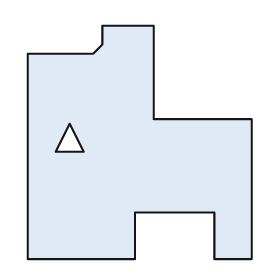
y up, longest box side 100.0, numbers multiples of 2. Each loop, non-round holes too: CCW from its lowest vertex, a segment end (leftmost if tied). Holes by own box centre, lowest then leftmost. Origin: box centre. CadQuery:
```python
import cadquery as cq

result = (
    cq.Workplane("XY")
    .moveTo(-48.0, -50.0)
    .lineTo(-2.0, -50.0)
    .lineTo(-2.0, -30.0)
    .lineTo(32.0, -30.0)
    .lineTo(32.0, -50.0)
    .lineTo(48.0, -50.0)
    .lineTo(48.0, 10.0)
    .lineTo(6.0, 10.0)
    .lineTo(6.0, 50.0)
    .lineTo(-16.0, 50.0)
    .lineTo(-16.0, 42.0)
    .lineTo(-20.0, 38.0)
    .lineTo(-48.0, 38.0)
    .close()
    .moveTo(-36.0, -4.0)
    .lineTo(-24.0, -4.0)
    .lineTo(-30.0, 8.0)
    .close()
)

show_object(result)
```